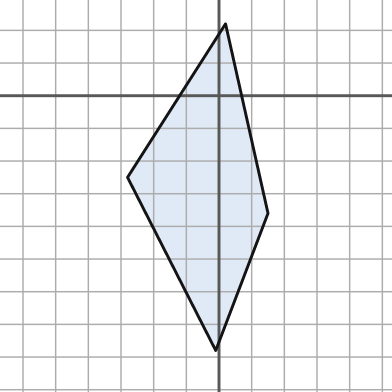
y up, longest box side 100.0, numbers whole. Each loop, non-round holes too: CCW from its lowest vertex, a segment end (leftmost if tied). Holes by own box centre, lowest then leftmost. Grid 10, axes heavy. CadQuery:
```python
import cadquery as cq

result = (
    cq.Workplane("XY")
    .moveTo(-1.0, -78.0)
    .lineTo(15.0, -36.0)
    .lineTo(2.0, 22.0)
    .lineTo(-28.0, -25.0)
    .close()
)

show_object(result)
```